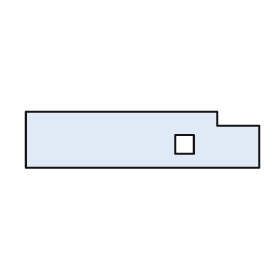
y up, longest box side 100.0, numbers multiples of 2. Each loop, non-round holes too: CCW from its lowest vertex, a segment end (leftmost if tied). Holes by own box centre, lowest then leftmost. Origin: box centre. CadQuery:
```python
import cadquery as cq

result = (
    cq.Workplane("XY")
    .moveTo(-50.0, -12.0)
    .lineTo(50.0, -12.0)
    .lineTo(50.0, 6.0)
    .lineTo(32.0, 6.0)
    .lineTo(32.0, 12.0)
    .lineTo(-50.0, 12.0)
    .close()
    .moveTo(14.0, -6.0)
    .lineTo(22.0, -6.0)
    .lineTo(22.0, 2.0)
    .lineTo(14.0, 2.0)
    .close()
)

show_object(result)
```